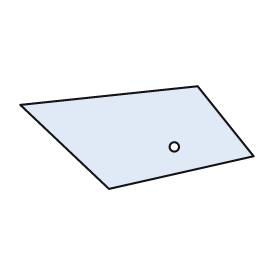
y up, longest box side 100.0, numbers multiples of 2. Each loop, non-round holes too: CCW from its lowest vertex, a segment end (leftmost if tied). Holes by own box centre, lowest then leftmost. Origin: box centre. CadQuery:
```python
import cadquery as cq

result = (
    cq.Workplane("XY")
    .moveTo(-12.0, -22.0)
    .lineTo(50.0, -8.0)
    .lineTo(26.0, 22.0)
    .lineTo(-50.0, 14.0)
    .close()
    .moveTo(16.0, -4.0)
    .circle(2.0)
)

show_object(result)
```